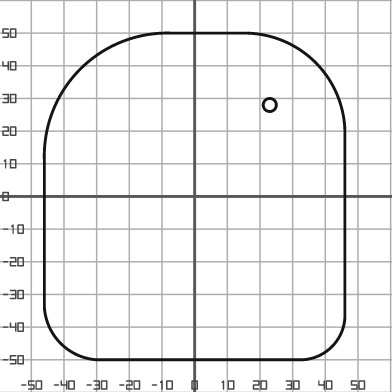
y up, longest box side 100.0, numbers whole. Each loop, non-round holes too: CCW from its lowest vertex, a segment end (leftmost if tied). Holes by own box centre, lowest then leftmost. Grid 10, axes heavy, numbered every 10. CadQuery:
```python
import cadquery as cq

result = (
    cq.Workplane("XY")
    .moveTo(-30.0, -50.0)
    .lineTo(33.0, -50.0)
    .threePointArc((42.0, -46.0), (46.0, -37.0))
    .lineTo(46.0, 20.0)
    .threePointArc((37.0, 41.0), (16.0, 50.0))
    .lineTo(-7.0, 50.0)
    .threePointArc((-35.0, 39.0), (-46.0, 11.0))
    .lineTo(-46.0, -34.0)
    .threePointArc((-41.0, -45.0), (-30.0, -50.0))
    .close()
    .moveTo(23.0, 28.0)
    .circle(2.0)
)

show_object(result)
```